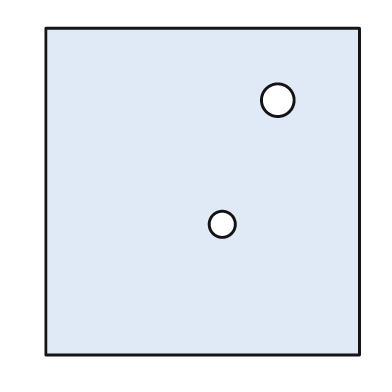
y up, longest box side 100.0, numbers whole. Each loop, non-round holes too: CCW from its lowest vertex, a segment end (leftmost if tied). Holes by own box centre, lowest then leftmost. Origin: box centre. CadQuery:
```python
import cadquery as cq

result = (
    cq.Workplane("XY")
    .moveTo(-48.0, -50.0)
    .lineTo(48.0, -50.0)
    .lineTo(48.0, 50.0)
    .lineTo(-48.0, 50.0)
    .close()
    .moveTo(6.0, -10.0)
    .circle(4.0)
    .moveTo(23.0, 28.0)
    .circle(5.0)
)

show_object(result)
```